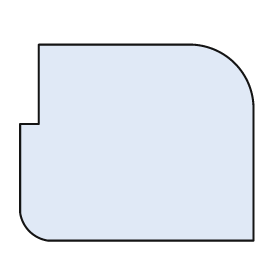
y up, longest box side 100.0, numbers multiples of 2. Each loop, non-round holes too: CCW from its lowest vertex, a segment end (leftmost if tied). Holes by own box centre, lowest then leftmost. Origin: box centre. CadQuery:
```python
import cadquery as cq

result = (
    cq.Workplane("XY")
    .moveTo(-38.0, -42.0)
    .lineTo(50.0, -42.0)
    .lineTo(50.0, 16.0)
    .threePointArc((42.0, 34.0), (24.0, 42.0))
    .lineTo(-42.0, 42.0)
    .lineTo(-42.0, 8.0)
    .lineTo(-50.0, 8.0)
    .lineTo(-50.0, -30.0)
    .threePointArc((-46.0, -38.0), (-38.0, -42.0))
    .close()
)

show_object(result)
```